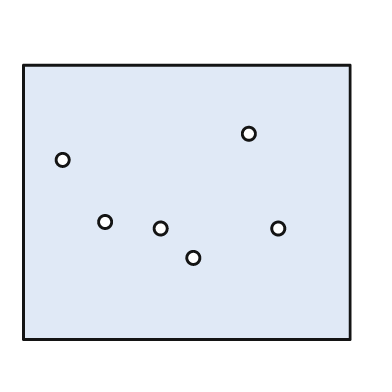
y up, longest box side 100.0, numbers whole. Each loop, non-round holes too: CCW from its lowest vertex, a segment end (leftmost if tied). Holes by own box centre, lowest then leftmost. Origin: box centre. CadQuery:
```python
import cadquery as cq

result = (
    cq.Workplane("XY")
    .moveTo(-50.0, -42.0)
    .lineTo(50.0, -42.0)
    .lineTo(50.0, 42.0)
    .lineTo(-50.0, 42.0)
    .close()
    .moveTo(2.0, -17.0)
    .circle(2.0)
    .moveTo(-8.0, -8.0)
    .circle(2.0)
    .moveTo(28.0, -8.0)
    .circle(2.0)
    .moveTo(-25.0, -6.0)
    .circle(2.0)
    .moveTo(-38.0, 13.0)
    .circle(2.0)
    .moveTo(19.0, 21.0)
    .circle(2.0)
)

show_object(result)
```